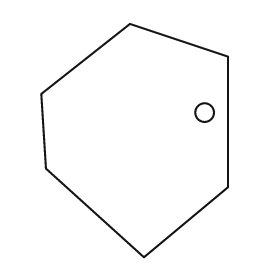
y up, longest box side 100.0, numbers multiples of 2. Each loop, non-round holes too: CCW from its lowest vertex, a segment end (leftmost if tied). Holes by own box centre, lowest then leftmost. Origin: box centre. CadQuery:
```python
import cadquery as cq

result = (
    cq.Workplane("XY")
    .moveTo(4.0, -50.0)
    .lineTo(40.0, -20.0)
    .lineTo(40.0, 36.0)
    .lineTo(-2.0, 50.0)
    .lineTo(-40.0, 20.0)
    .lineTo(-38.0, -12.0)
    .close()
    .moveTo(30.0, 12.0)
    .circle(4.0)
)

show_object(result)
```